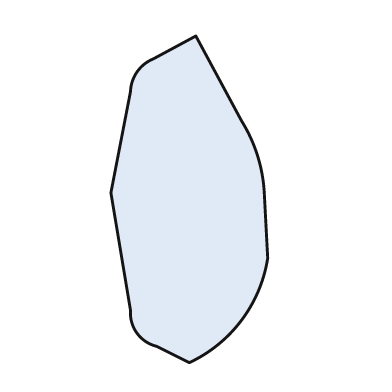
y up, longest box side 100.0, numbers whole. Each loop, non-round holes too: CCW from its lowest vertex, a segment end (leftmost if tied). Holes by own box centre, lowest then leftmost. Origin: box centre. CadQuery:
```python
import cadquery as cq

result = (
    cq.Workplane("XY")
    .moveTo(0.0, -50.0)
    .threePointArc((16.0, -37.0), (24.0, -18.0))
    .lineTo(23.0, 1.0)
    .threePointArc((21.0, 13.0), (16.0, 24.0))
    .lineTo(2.0, 50.0)
    .lineTo(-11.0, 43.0)
    .threePointArc((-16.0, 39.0), (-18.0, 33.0))
    .lineTo(-24.0, 2.0)
    .lineTo(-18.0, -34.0)
    .threePointArc((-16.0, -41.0), (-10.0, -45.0))
    .close()
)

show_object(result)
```